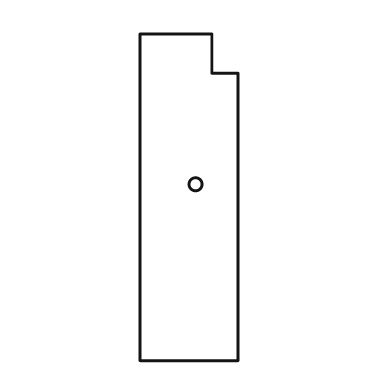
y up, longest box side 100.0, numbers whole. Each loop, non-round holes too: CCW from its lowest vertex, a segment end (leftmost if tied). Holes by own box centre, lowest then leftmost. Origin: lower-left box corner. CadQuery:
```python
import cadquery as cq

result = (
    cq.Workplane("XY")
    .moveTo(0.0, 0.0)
    .lineTo(30.0, 0.0)
    .lineTo(30.0, 88.0)
    .lineTo(22.0, 88.0)
    .lineTo(22.0, 100.0)
    .lineTo(0.0, 100.0)
    .close()
    .moveTo(17.0, 54.0)
    .circle(2.0)
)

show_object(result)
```